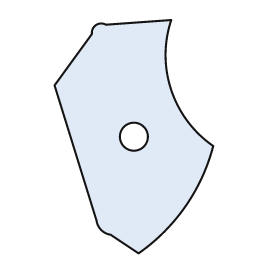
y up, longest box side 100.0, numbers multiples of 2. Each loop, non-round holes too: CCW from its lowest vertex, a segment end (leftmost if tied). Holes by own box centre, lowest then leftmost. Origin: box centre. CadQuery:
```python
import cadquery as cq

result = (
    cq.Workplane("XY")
    .moveTo(2.0, -50.0)
    .threePointArc((22.0, -30.0), (34.0, -4.0))
    .threePointArc((16.0, 20.0), (16.0, 50.0))
    .lineTo(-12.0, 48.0)
    .threePointArc((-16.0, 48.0), (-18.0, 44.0))
    .lineTo(-34.0, 22.0)
    .lineTo(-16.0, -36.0)
    .threePointArc((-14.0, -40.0), (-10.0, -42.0))
    .close()
    .moveTo(0.0, 0.0)
    .circle(6.0)
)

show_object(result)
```